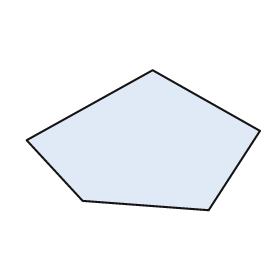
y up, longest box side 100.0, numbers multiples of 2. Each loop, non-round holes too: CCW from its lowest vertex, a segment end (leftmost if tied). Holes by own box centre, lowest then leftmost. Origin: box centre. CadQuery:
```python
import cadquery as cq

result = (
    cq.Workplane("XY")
    .moveTo(28.0, -30.0)
    .lineTo(50.0, 4.0)
    .lineTo(4.0, 30.0)
    .lineTo(-50.0, 0.0)
    .lineTo(-26.0, -26.0)
    .close()
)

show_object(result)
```